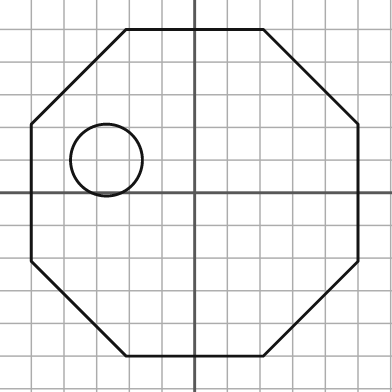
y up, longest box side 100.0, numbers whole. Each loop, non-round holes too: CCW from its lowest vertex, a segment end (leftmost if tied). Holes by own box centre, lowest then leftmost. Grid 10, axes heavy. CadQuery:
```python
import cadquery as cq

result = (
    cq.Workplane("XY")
    .moveTo(-21.0, -50.0)
    .lineTo(21.0, -50.0)
    .lineTo(50.0, -21.0)
    .lineTo(50.0, 21.0)
    .lineTo(21.0, 50.0)
    .lineTo(-21.0, 50.0)
    .lineTo(-50.0, 21.0)
    .lineTo(-50.0, -21.0)
    .close()
    .moveTo(-27.0, 10.0)
    .circle(11.0)
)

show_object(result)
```